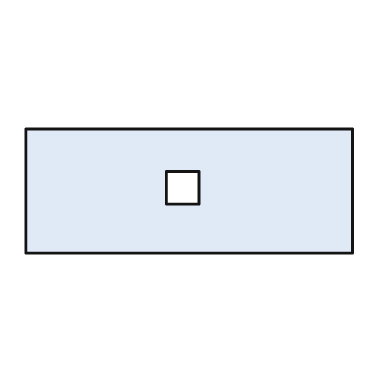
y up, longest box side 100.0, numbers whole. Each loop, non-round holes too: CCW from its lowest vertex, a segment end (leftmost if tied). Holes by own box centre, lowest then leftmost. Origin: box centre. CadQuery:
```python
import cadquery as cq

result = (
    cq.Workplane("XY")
    .moveTo(-50.0, -19.0)
    .lineTo(50.0, -19.0)
    .lineTo(50.0, 19.0)
    .lineTo(-50.0, 19.0)
    .close()
    .moveTo(-7.0, -4.0)
    .lineTo(3.0, -4.0)
    .lineTo(3.0, 6.0)
    .lineTo(-7.0, 6.0)
    .close()
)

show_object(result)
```